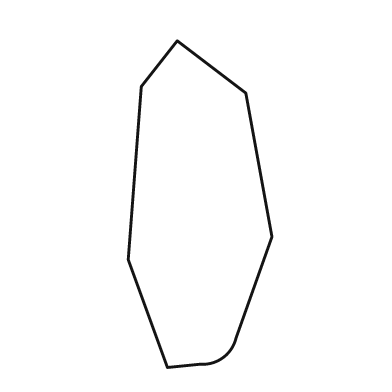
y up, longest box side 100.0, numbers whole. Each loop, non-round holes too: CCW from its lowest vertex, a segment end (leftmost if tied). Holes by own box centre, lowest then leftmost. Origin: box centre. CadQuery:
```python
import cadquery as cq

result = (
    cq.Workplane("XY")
    .moveTo(-10.0, -50.0)
    .lineTo(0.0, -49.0)
    .threePointArc((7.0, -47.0), (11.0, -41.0))
    .lineTo(22.0, -10.0)
    .lineTo(14.0, 34.0)
    .lineTo(-7.0, 50.0)
    .lineTo(-18.0, 36.0)
    .lineTo(-22.0, -17.0)
    .close()
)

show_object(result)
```